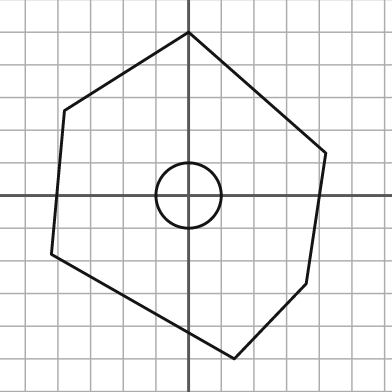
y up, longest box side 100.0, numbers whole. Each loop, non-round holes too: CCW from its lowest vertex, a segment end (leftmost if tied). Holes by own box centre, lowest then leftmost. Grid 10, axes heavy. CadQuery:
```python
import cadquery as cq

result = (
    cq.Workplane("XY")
    .moveTo(14.0, -50.0)
    .lineTo(36.0, -27.0)
    .lineTo(42.0, 13.0)
    .lineTo(0.0, 50.0)
    .lineTo(-38.0, 26.0)
    .lineTo(-42.0, -18.0)
    .close()
    .moveTo(0.0, 0.0)
    .circle(10.0)
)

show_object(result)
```